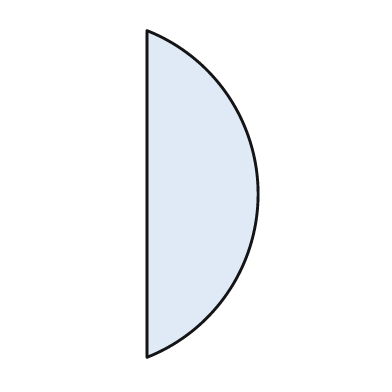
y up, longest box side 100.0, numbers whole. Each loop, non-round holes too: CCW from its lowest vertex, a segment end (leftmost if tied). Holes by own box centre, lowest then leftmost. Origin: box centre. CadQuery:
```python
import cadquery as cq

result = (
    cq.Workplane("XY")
    .moveTo(-17.0, -50.0)
    .threePointArc((17.0, 0.0), (-17.0, 50.0))
    .close()
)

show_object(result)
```